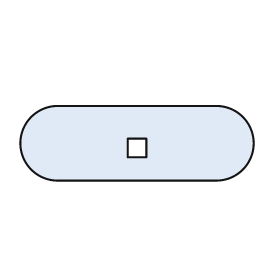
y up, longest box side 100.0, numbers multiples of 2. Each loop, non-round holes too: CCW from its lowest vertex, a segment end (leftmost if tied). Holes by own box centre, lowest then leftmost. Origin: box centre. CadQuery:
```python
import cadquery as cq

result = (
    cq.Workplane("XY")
    .moveTo(-34.0, -16.0)
    .lineTo(34.0, -16.0)
    .threePointArc((50.0, 0.0), (34.0, 16.0))
    .lineTo(-34.0, 16.0)
    .threePointArc((-50.0, 0.0), (-34.0, -16.0))
    .close()
    .moveTo(-4.0, -6.0)
    .lineTo(4.0, -6.0)
    .lineTo(4.0, 2.0)
    .lineTo(-4.0, 2.0)
    .close()
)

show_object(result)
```